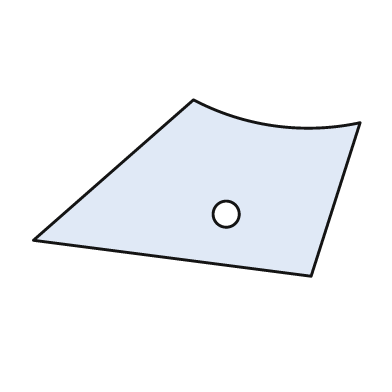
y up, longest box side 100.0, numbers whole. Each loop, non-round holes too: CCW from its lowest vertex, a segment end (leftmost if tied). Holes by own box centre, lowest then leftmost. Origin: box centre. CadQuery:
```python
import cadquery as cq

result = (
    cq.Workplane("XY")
    .moveTo(35.0, -27.0)
    .lineTo(50.0, 20.0)
    .threePointArc((24.0, 19.0), (-1.0, 27.0))
    .lineTo(-50.0, -16.0)
    .close()
    .moveTo(9.0, -8.0)
    .circle(4.0)
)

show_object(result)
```